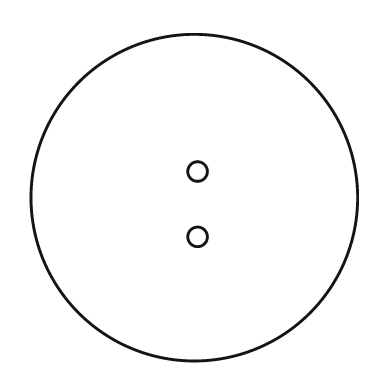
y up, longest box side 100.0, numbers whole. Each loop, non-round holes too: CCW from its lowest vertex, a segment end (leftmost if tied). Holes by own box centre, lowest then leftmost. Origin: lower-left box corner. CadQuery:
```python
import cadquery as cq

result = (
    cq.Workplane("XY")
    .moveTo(50.0, 50.0)
    .circle(50.0)
    .moveTo(51.0, 38.0)
    .circle(3.0)
    .moveTo(51.0, 58.0)
    .circle(3.0)
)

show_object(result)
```